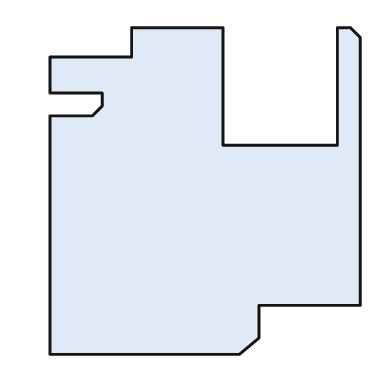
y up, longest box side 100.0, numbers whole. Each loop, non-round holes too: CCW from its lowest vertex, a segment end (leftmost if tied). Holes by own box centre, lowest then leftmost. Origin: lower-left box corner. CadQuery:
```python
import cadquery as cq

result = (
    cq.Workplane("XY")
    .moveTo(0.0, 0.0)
    .lineTo(58.0, 0.0)
    .lineTo(64.0, 5.0)
    .lineTo(64.0, 15.0)
    .lineTo(95.0, 15.0)
    .lineTo(95.0, 97.0)
    .lineTo(92.0, 100.0)
    .lineTo(88.0, 100.0)
    .lineTo(88.0, 64.0)
    .lineTo(53.0, 64.0)
    .lineTo(53.0, 100.0)
    .lineTo(25.0, 100.0)
    .lineTo(25.0, 91.0)
    .lineTo(0.0, 91.0)
    .lineTo(0.0, 80.0)
    .lineTo(16.0, 80.0)
    .lineTo(16.0, 76.0)
    .lineTo(13.0, 73.0)
    .lineTo(0.0, 73.0)
    .close()
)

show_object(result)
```